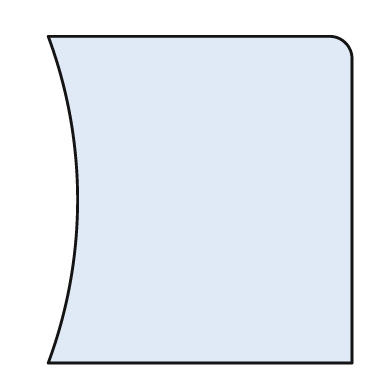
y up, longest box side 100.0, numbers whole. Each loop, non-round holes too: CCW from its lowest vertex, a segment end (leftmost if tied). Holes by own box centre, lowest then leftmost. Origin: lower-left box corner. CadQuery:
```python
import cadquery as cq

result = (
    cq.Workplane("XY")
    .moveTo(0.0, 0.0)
    .lineTo(93.0, 0.0)
    .lineTo(93.0, 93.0)
    .threePointArc((91.0, 98.0), (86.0, 100.0))
    .lineTo(0.0, 100.0)
    .threePointArc((9.0, 50.0), (0.0, 0.0))
    .close()
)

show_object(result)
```